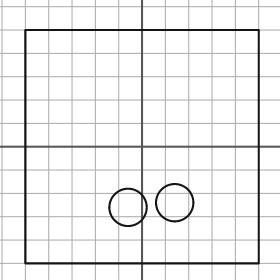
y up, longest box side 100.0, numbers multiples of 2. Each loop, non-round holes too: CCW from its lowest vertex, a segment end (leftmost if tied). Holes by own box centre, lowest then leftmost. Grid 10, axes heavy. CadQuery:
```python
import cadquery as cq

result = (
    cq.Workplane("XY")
    .moveTo(-50.0, -50.0)
    .lineTo(50.0, -50.0)
    .lineTo(50.0, 50.0)
    .lineTo(-50.0, 50.0)
    .close()
    .moveTo(-6.0, -26.0)
    .circle(8.0)
    .moveTo(14.0, -24.0)
    .circle(8.0)
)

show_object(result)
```